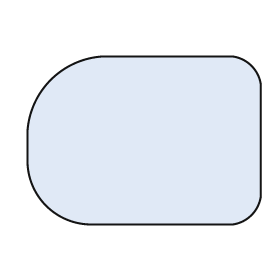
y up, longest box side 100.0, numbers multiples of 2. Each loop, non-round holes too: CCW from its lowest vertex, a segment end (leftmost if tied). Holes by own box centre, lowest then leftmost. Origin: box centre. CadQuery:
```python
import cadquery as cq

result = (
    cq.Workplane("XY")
    .moveTo(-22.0, -36.0)
    .lineTo(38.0, -36.0)
    .threePointArc((46.0, -32.0), (50.0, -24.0))
    .lineTo(50.0, 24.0)
    .threePointArc((46.0, 32.0), (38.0, 36.0))
    .lineTo(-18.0, 36.0)
    .threePointArc((-40.0, 26.0), (-50.0, 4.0))
    .lineTo(-50.0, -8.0)
    .threePointArc((-42.0, -28.0), (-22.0, -36.0))
    .close()
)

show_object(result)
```